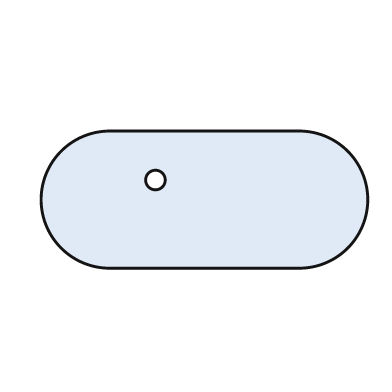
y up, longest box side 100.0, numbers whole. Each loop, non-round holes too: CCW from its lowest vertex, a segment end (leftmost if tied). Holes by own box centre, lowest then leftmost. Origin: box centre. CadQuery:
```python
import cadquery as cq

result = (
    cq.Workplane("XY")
    .moveTo(-29.0, -21.0)
    .lineTo(29.0, -21.0)
    .threePointArc((50.0, 0.0), (29.0, 21.0))
    .lineTo(-29.0, 21.0)
    .threePointArc((-50.0, 0.0), (-29.0, -21.0))
    .close()
    .moveTo(-15.0, 6.0)
    .circle(3.0)
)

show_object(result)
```